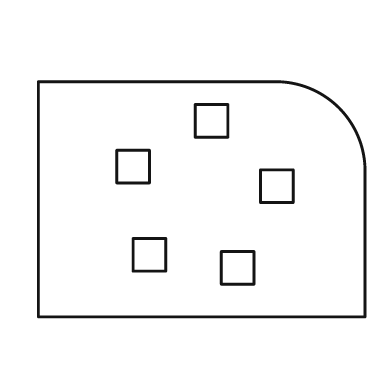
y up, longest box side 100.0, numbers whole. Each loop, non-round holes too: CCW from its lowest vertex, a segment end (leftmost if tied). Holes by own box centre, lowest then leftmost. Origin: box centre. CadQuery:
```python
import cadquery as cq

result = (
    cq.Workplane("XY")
    .moveTo(-50.0, -36.0)
    .lineTo(50.0, -36.0)
    .lineTo(50.0, 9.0)
    .threePointArc((42.0, 28.0), (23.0, 36.0))
    .lineTo(-50.0, 36.0)
    .close()
    .moveTo(6.0, -26.0)
    .lineTo(16.0, -26.0)
    .lineTo(16.0, -16.0)
    .lineTo(6.0, -16.0)
    .close()
    .moveTo(-21.0, -22.0)
    .lineTo(-11.0, -22.0)
    .lineTo(-11.0, -12.0)
    .lineTo(-21.0, -12.0)
    .close()
    .moveTo(18.0, -1.0)
    .lineTo(28.0, -1.0)
    .lineTo(28.0, 9.0)
    .lineTo(18.0, 9.0)
    .close()
    .moveTo(-26.0, 5.0)
    .lineTo(-16.0, 5.0)
    .lineTo(-16.0, 15.0)
    .lineTo(-26.0, 15.0)
    .close()
    .moveTo(-2.0, 19.0)
    .lineTo(8.0, 19.0)
    .lineTo(8.0, 29.0)
    .lineTo(-2.0, 29.0)
    .close()
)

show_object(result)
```